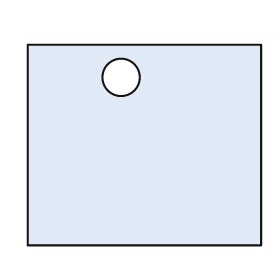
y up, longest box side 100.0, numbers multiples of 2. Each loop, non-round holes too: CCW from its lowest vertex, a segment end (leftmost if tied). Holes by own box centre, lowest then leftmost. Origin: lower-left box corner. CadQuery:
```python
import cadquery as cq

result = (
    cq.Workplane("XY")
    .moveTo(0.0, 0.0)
    .lineTo(100.0, 0.0)
    .lineTo(100.0, 86.0)
    .lineTo(0.0, 86.0)
    .close()
    .moveTo(40.0, 72.0)
    .circle(8.0)
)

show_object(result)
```